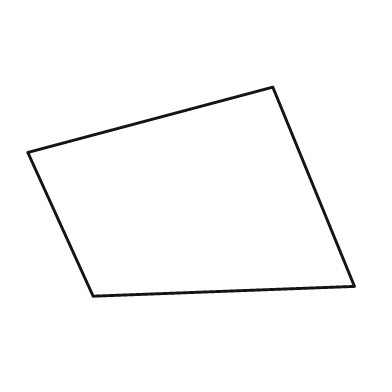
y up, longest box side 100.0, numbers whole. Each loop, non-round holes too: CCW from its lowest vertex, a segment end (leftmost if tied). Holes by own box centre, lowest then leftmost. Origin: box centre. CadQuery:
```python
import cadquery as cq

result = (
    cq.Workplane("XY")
    .moveTo(-30.0, -32.0)
    .lineTo(50.0, -29.0)
    .lineTo(25.0, 32.0)
    .lineTo(-50.0, 12.0)
    .close()
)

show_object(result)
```